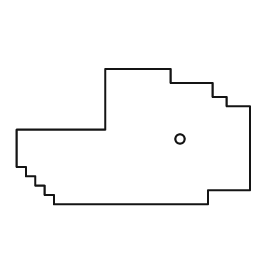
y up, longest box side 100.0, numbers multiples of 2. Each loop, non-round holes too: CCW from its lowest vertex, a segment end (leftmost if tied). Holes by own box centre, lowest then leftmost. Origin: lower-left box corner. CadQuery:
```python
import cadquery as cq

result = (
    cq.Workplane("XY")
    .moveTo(16.0, 0.0)
    .lineTo(82.0, 0.0)
    .lineTo(82.0, 6.0)
    .lineTo(100.0, 6.0)
    .lineTo(100.0, 42.0)
    .lineTo(90.0, 42.0)
    .lineTo(90.0, 46.0)
    .lineTo(84.0, 46.0)
    .lineTo(84.0, 52.0)
    .lineTo(66.0, 52.0)
    .lineTo(66.0, 58.0)
    .lineTo(38.0, 58.0)
    .lineTo(38.0, 32.0)
    .lineTo(0.0, 32.0)
    .lineTo(0.0, 16.0)
    .lineTo(4.0, 16.0)
    .lineTo(4.0, 12.0)
    .lineTo(8.0, 12.0)
    .lineTo(8.0, 8.0)
    .lineTo(12.0, 8.0)
    .lineTo(12.0, 4.0)
    .lineTo(16.0, 4.0)
    .close()
    .moveTo(70.0, 28.0)
    .circle(2.0)
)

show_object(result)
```